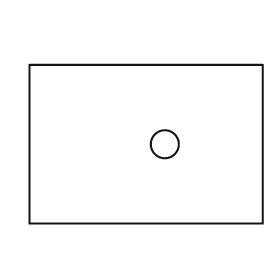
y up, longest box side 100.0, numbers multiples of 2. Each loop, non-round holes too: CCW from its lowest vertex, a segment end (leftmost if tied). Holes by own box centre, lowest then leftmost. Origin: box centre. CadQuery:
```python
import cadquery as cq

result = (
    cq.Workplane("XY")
    .moveTo(-50.0, -34.0)
    .lineTo(50.0, -34.0)
    .lineTo(50.0, 34.0)
    .lineTo(-50.0, 34.0)
    .close()
    .moveTo(8.0, 0.0)
    .circle(6.0)
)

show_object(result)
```